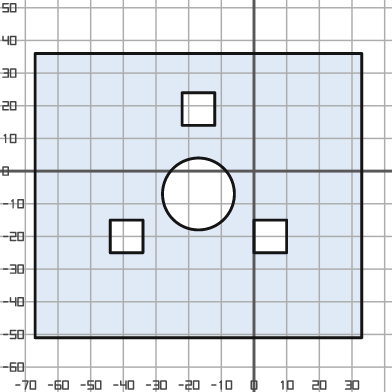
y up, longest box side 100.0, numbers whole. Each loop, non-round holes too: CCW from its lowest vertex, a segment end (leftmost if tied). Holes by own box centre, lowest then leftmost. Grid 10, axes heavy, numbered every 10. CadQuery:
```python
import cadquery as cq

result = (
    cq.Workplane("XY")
    .moveTo(-67.0, -51.0)
    .lineTo(33.0, -51.0)
    .lineTo(33.0, 36.0)
    .lineTo(-67.0, 36.0)
    .close()
    .moveTo(-44.0, -25.0)
    .lineTo(-34.0, -25.0)
    .lineTo(-34.0, -15.0)
    .lineTo(-44.0, -15.0)
    .close()
    .moveTo(0.0, -25.0)
    .lineTo(10.0, -25.0)
    .lineTo(10.0, -15.0)
    .lineTo(0.0, -15.0)
    .close()
    .moveTo(-17.0, -7.0)
    .circle(11.0)
    .moveTo(-22.0, 14.0)
    .lineTo(-12.0, 14.0)
    .lineTo(-12.0, 24.0)
    .lineTo(-22.0, 24.0)
    .close()
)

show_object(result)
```